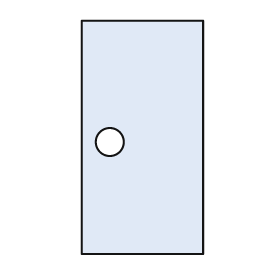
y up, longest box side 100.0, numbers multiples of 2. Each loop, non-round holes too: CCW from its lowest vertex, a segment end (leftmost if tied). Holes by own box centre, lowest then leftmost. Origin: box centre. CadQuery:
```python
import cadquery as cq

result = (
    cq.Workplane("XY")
    .moveTo(-26.0, -50.0)
    .lineTo(26.0, -50.0)
    .lineTo(26.0, 50.0)
    .lineTo(-26.0, 50.0)
    .close()
    .moveTo(-14.0, -2.0)
    .circle(6.0)
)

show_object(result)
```